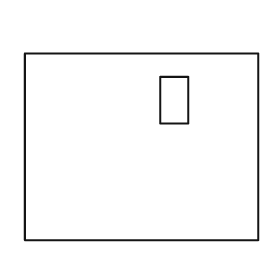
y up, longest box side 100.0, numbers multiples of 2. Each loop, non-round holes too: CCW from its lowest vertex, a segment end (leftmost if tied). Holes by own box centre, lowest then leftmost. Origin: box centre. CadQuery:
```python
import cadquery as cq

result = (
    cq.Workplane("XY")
    .moveTo(-50.0, -40.0)
    .lineTo(50.0, -40.0)
    .lineTo(50.0, 40.0)
    .lineTo(-50.0, 40.0)
    .close()
    .moveTo(8.0, 10.0)
    .lineTo(20.0, 10.0)
    .lineTo(20.0, 30.0)
    .lineTo(8.0, 30.0)
    .close()
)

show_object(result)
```